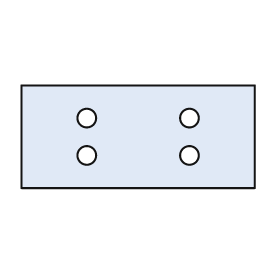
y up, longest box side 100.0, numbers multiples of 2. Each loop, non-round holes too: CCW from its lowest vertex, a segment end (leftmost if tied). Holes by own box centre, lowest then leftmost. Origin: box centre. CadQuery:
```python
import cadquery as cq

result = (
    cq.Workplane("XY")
    .moveTo(-50.0, -22.0)
    .lineTo(50.0, -22.0)
    .lineTo(50.0, 22.0)
    .lineTo(-50.0, 22.0)
    .close()
    .moveTo(-22.0, -8.0)
    .circle(4.0)
    .moveTo(22.0, -8.0)
    .circle(4.0)
    .moveTo(-22.0, 8.0)
    .circle(4.0)
    .moveTo(22.0, 8.0)
    .circle(4.0)
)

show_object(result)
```